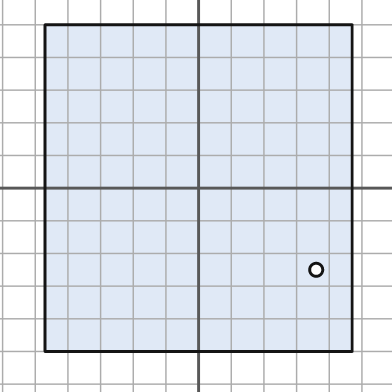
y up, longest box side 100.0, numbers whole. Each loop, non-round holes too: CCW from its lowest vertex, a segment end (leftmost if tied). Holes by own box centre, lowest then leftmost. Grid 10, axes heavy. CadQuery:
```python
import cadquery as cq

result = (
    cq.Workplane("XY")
    .moveTo(-47.0, -50.0)
    .lineTo(47.0, -50.0)
    .lineTo(47.0, 50.0)
    .lineTo(-47.0, 50.0)
    .close()
    .moveTo(36.0, -25.0)
    .circle(2.0)
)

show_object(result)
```